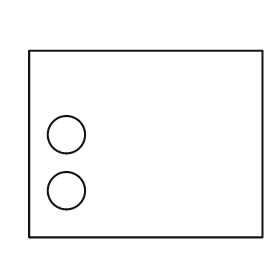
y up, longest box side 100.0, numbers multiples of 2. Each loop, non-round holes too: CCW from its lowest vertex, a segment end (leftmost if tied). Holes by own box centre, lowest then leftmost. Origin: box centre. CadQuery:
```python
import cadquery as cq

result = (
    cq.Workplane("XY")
    .moveTo(-50.0, -40.0)
    .lineTo(50.0, -40.0)
    .lineTo(50.0, 40.0)
    .lineTo(-50.0, 40.0)
    .close()
    .moveTo(-34.0, -20.0)
    .circle(8.0)
    .moveTo(-34.0, 4.0)
    .circle(8.0)
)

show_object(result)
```